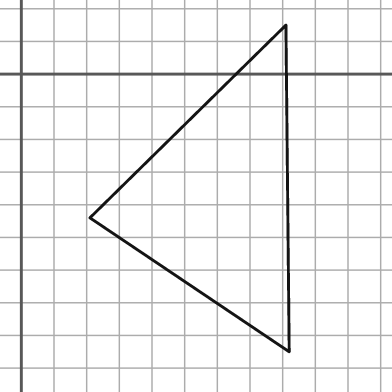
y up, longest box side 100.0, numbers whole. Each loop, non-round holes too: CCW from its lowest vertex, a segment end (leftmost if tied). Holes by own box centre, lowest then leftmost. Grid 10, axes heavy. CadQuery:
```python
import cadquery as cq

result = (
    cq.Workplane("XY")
    .moveTo(82.0, -85.0)
    .lineTo(81.0, 15.0)
    .lineTo(21.0, -44.0)
    .close()
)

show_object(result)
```